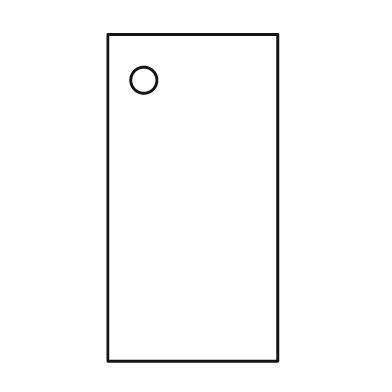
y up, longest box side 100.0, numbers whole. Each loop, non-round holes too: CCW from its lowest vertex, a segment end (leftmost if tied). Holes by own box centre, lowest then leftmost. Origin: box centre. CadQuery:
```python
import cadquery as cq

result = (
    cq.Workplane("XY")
    .moveTo(-26.0, -50.0)
    .lineTo(26.0, -50.0)
    .lineTo(26.0, 50.0)
    .lineTo(-26.0, 50.0)
    .close()
    .moveTo(-15.0, 36.0)
    .circle(4.0)
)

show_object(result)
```